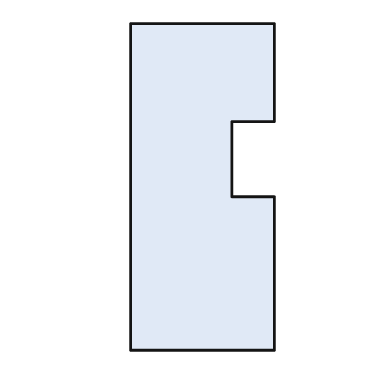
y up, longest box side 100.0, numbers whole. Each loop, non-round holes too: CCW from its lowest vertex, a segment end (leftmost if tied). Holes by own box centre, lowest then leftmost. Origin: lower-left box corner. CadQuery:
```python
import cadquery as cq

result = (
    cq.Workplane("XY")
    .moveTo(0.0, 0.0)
    .lineTo(44.0, 0.0)
    .lineTo(44.0, 47.0)
    .lineTo(31.0, 47.0)
    .lineTo(31.0, 70.0)
    .lineTo(44.0, 70.0)
    .lineTo(44.0, 100.0)
    .lineTo(0.0, 100.0)
    .close()
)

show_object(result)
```